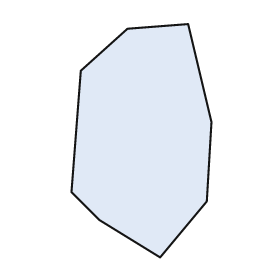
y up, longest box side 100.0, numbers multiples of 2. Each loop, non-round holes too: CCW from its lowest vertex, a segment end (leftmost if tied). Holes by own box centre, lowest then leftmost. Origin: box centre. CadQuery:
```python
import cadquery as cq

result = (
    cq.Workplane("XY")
    .moveTo(8.0, -50.0)
    .lineTo(28.0, -26.0)
    .lineTo(30.0, 8.0)
    .lineTo(20.0, 50.0)
    .lineTo(-6.0, 48.0)
    .lineTo(-26.0, 30.0)
    .lineTo(-30.0, -22.0)
    .lineTo(-18.0, -34.0)
    .close()
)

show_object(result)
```